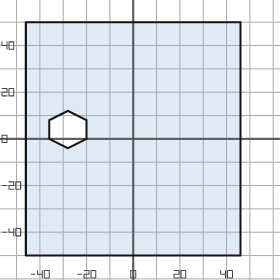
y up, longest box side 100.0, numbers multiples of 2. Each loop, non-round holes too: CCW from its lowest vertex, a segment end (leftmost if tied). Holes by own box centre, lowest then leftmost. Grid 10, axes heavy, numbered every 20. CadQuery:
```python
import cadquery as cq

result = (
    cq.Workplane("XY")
    .moveTo(-46.0, -50.0)
    .lineTo(46.0, -50.0)
    .lineTo(46.0, 50.0)
    .lineTo(-46.0, 50.0)
    .close()
    .moveTo(-28.0, -4.0)
    .lineTo(-20.0, 0.0)
    .lineTo(-20.0, 8.0)
    .lineTo(-28.0, 12.0)
    .lineTo(-36.0, 8.0)
    .lineTo(-36.0, 0.0)
    .close()
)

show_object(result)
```